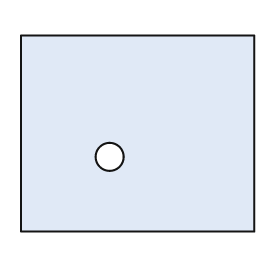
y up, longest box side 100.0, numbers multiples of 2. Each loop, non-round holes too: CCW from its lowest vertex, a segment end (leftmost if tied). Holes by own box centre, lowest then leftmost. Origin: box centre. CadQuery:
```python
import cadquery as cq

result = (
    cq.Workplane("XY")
    .moveTo(-50.0, -42.0)
    .lineTo(50.0, -42.0)
    .lineTo(50.0, 42.0)
    .lineTo(-50.0, 42.0)
    .close()
    .moveTo(-12.0, -10.0)
    .circle(6.0)
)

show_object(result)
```